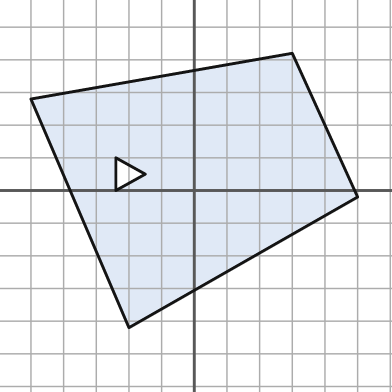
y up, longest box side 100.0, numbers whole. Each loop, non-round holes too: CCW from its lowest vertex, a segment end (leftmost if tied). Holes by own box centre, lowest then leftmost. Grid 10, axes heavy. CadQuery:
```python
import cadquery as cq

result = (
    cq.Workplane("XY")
    .moveTo(-20.0, -42.0)
    .lineTo(50.0, -2.0)
    .lineTo(30.0, 42.0)
    .lineTo(-50.0, 28.0)
    .close()
    .moveTo(-24.0, 0.0)
    .lineTo(-15.0, 5.0)
    .lineTo(-24.0, 10.0)
    .close()
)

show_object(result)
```